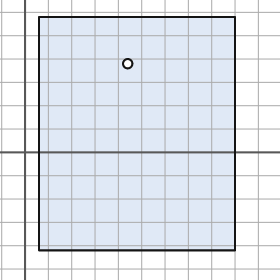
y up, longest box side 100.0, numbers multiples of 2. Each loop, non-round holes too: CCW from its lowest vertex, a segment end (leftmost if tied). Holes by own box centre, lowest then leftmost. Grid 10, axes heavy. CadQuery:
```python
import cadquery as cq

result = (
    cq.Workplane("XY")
    .moveTo(6.0, -42.0)
    .lineTo(90.0, -42.0)
    .lineTo(90.0, 58.0)
    .lineTo(6.0, 58.0)
    .close()
    .moveTo(44.0, 38.0)
    .circle(2.0)
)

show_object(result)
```